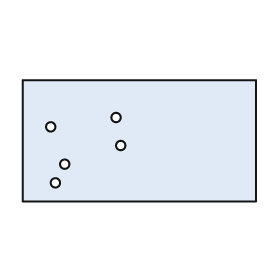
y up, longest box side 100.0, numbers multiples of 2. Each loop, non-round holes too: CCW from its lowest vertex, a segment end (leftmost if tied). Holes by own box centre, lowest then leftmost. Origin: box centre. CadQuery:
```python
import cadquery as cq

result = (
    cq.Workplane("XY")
    .moveTo(-50.0, -26.0)
    .lineTo(50.0, -26.0)
    .lineTo(50.0, 26.0)
    .lineTo(-50.0, 26.0)
    .close()
    .moveTo(-36.0, -18.0)
    .circle(2.0)
    .moveTo(-32.0, -10.0)
    .circle(2.0)
    .moveTo(-8.0, -2.0)
    .circle(2.0)
    .moveTo(-38.0, 6.0)
    .circle(2.0)
    .moveTo(-10.0, 10.0)
    .circle(2.0)
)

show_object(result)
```